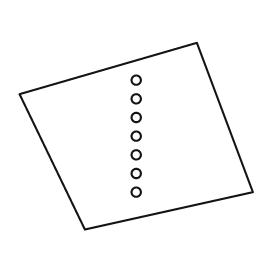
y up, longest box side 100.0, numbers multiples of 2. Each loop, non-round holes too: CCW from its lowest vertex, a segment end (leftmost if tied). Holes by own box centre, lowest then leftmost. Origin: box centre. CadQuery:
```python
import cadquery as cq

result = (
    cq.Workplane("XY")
    .moveTo(-22.0, -40.0)
    .lineTo(50.0, -24.0)
    .lineTo(26.0, 40.0)
    .lineTo(-50.0, 18.0)
    .close()
    .moveTo(0.0, -24.0)
    .circle(2.0)
    .moveTo(0.0, -16.0)
    .circle(2.0)
    .moveTo(0.0, -8.0)
    .circle(2.0)
    .moveTo(0.0, 0.0)
    .circle(2.0)
    .moveTo(0.0, 8.0)
    .circle(2.0)
    .moveTo(0.0, 16.0)
    .circle(2.0)
    .moveTo(0.0, 24.0)
    .circle(2.0)
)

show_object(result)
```